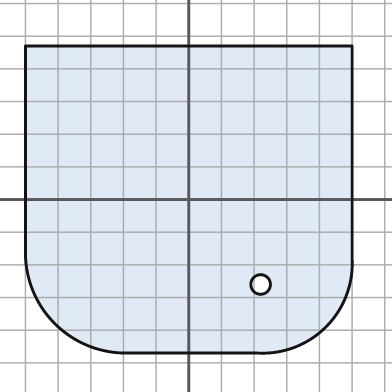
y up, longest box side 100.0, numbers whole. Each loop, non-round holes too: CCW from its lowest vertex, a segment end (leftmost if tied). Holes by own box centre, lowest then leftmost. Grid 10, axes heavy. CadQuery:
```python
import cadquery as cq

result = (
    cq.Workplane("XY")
    .moveTo(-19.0, -47.0)
    .lineTo(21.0, -47.0)
    .threePointArc((42.0, -39.0), (50.0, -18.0))
    .lineTo(50.0, 47.0)
    .lineTo(-50.0, 47.0)
    .lineTo(-50.0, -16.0)
    .threePointArc((-41.0, -38.0), (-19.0, -47.0))
    .close()
    .moveTo(22.0, -26.0)
    .circle(3.0)
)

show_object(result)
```